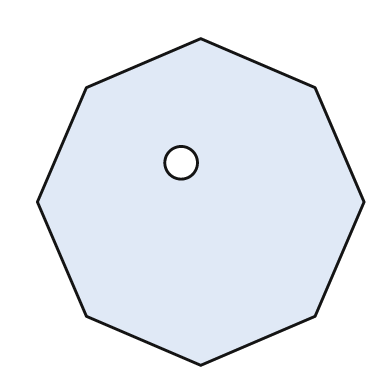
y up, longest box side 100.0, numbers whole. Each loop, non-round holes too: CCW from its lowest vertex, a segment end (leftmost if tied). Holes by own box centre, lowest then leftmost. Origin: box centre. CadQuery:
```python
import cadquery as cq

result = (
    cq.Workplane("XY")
    .moveTo(0.0, -50.0)
    .lineTo(35.0, -35.0)
    .lineTo(50.0, 0.0)
    .lineTo(35.0, 35.0)
    .lineTo(0.0, 50.0)
    .lineTo(-35.0, 35.0)
    .lineTo(-50.0, 0.0)
    .lineTo(-35.0, -35.0)
    .close()
    .moveTo(-6.0, 12.0)
    .circle(5.0)
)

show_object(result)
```